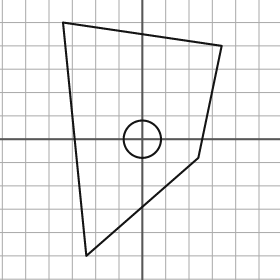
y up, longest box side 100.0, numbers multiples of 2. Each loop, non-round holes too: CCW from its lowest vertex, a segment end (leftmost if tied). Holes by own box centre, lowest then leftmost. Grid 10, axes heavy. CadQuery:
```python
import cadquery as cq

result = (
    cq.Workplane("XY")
    .moveTo(-24.0, -50.0)
    .lineTo(24.0, -8.0)
    .lineTo(34.0, 40.0)
    .lineTo(-34.0, 50.0)
    .close()
    .moveTo(0.0, 0.0)
    .circle(8.0)
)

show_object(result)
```